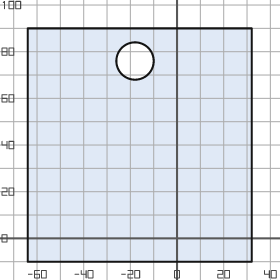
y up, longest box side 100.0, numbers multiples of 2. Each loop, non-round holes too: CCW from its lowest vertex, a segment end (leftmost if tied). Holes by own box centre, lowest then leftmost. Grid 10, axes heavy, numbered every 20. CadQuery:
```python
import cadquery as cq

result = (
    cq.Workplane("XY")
    .moveTo(-64.0, -10.0)
    .lineTo(32.0, -10.0)
    .lineTo(32.0, 90.0)
    .lineTo(-64.0, 90.0)
    .close()
    .moveTo(-18.0, 76.0)
    .circle(8.0)
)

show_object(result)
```